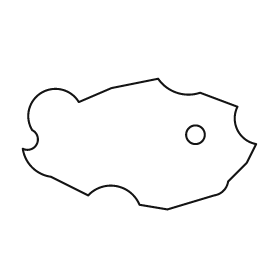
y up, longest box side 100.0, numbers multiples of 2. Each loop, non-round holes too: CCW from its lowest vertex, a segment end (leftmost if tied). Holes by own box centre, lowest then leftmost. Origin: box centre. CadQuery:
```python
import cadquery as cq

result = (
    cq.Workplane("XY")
    .moveTo(12.0, -28.0)
    .lineTo(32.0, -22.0)
    .threePointArc((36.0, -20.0), (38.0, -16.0))
    .lineTo(46.0, -8.0)
    .lineTo(50.0, 0.0)
    .threePointArc((42.0, 6.0), (42.0, 16.0))
    .lineTo(26.0, 22.0)
    .threePointArc((16.0, 22.0), (8.0, 28.0))
    .lineTo(-12.0, 24.0)
    .lineTo(-26.0, 18.0)
    .threePointArc((-42.0, 22.0), (-46.0, 6.0))
    .threePointArc((-44.0, 0.0), (-50.0, -2.0))
    .threePointArc((-46.0, -10.0), (-38.0, -14.0))
    .lineTo(-22.0, -22.0)
    .threePointArc((-10.0, -18.0), (0.0, -26.0))
    .close()
    .moveTo(24.0, 4.0)
    .circle(4.0)
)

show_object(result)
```